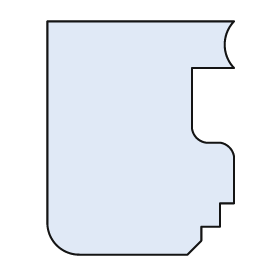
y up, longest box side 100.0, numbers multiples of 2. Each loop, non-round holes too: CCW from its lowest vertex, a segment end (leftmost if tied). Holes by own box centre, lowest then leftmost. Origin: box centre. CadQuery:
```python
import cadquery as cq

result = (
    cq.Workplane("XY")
    .moveTo(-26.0, -50.0)
    .lineTo(20.0, -50.0)
    .lineTo(26.0, -44.0)
    .lineTo(26.0, -38.0)
    .lineTo(34.0, -38.0)
    .lineTo(34.0, -28.0)
    .lineTo(40.0, -28.0)
    .lineTo(40.0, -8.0)
    .threePointArc((38.0, -4.0), (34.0, -2.0))
    .lineTo(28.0, -2.0)
    .threePointArc((24.0, 0.0), (22.0, 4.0))
    .lineTo(22.0, 30.0)
    .lineTo(40.0, 30.0)
    .threePointArc((36.0, 40.0), (40.0, 50.0))
    .lineTo(-40.0, 50.0)
    .lineTo(-40.0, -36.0)
    .threePointArc((-36.0, -46.0), (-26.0, -50.0))
    .close()
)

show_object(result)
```